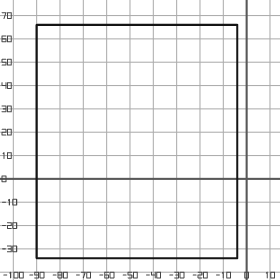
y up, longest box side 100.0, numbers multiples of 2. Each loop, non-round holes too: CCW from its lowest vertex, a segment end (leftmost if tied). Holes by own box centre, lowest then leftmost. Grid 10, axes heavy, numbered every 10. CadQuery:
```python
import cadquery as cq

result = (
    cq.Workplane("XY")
    .moveTo(-90.0, -34.0)
    .lineTo(-4.0, -34.0)
    .lineTo(-4.0, 66.0)
    .lineTo(-90.0, 66.0)
    .close()
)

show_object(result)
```